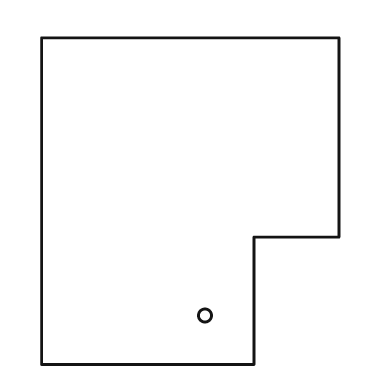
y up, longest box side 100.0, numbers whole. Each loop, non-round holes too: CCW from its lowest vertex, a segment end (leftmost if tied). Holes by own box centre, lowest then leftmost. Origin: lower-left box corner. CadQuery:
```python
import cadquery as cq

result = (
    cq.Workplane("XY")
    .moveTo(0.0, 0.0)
    .lineTo(65.0, 0.0)
    .lineTo(65.0, 39.0)
    .lineTo(91.0, 39.0)
    .lineTo(91.0, 100.0)
    .lineTo(0.0, 100.0)
    .close()
    .moveTo(50.0, 15.0)
    .circle(2.0)
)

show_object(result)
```